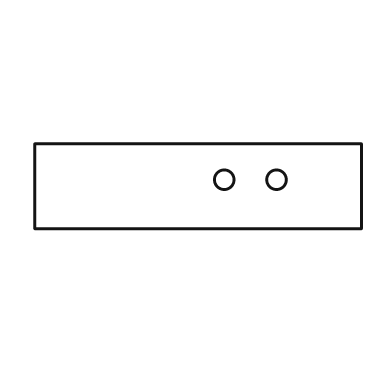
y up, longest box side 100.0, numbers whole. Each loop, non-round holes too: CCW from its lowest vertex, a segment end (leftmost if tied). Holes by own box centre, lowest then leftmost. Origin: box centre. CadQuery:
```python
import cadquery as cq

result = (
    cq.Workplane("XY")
    .moveTo(-50.0, -13.0)
    .lineTo(50.0, -13.0)
    .lineTo(50.0, 13.0)
    .lineTo(-50.0, 13.0)
    .close()
    .moveTo(8.0, 2.0)
    .circle(3.0)
    .moveTo(24.0, 2.0)
    .circle(3.0)
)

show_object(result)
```